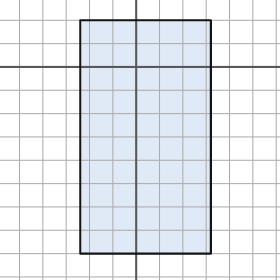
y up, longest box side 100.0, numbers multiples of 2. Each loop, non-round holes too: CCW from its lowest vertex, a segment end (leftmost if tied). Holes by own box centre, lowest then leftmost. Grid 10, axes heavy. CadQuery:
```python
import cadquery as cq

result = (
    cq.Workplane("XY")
    .moveTo(-24.0, -80.0)
    .lineTo(32.0, -80.0)
    .lineTo(32.0, 20.0)
    .lineTo(-24.0, 20.0)
    .close()
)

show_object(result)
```